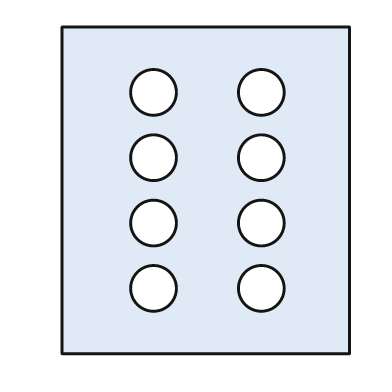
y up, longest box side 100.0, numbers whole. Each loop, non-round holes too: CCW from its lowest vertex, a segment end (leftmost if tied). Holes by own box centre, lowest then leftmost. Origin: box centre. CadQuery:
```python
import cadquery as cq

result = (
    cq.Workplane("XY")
    .moveTo(-44.0, -50.0)
    .lineTo(44.0, -50.0)
    .lineTo(44.0, 50.0)
    .lineTo(-44.0, 50.0)
    .close()
    .moveTo(-16.0, -30.0)
    .circle(7.0)
    .moveTo(17.0, -30.0)
    .circle(7.0)
    .moveTo(-16.0, -10.0)
    .circle(7.0)
    .moveTo(17.0, -10.0)
    .circle(7.0)
    .moveTo(-16.0, 10.0)
    .circle(7.0)
    .moveTo(17.0, 10.0)
    .circle(7.0)
    .moveTo(-16.0, 30.0)
    .circle(7.0)
    .moveTo(17.0, 30.0)
    .circle(7.0)
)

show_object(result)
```